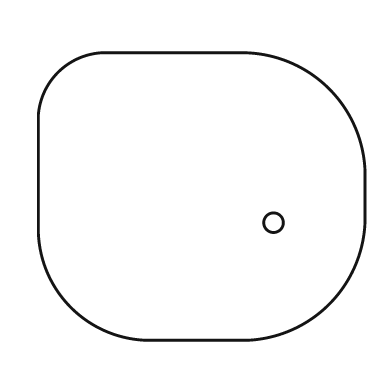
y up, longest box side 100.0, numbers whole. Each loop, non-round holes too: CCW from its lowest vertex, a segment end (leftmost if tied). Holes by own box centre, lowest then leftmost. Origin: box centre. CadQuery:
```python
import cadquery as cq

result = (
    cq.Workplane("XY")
    .moveTo(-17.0, -44.0)
    .lineTo(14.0, -44.0)
    .threePointArc((39.0, -33.0), (50.0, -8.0))
    .lineTo(50.0, 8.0)
    .threePointArc((39.0, 33.0), (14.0, 44.0))
    .lineTo(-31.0, 44.0)
    .threePointArc((-44.0, 38.0), (-50.0, 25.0))
    .lineTo(-50.0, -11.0)
    .threePointArc((-40.0, -34.0), (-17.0, -44.0))
    .close()
    .moveTo(22.0, -8.0)
    .circle(3.0)
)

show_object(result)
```